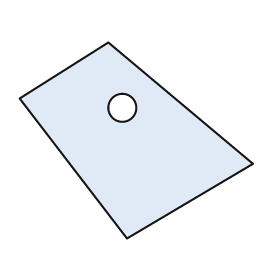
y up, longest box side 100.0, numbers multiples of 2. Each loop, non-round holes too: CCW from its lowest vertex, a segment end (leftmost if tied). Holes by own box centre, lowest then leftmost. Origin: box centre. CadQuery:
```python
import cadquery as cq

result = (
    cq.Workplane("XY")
    .moveTo(-4.0, -42.0)
    .lineTo(50.0, -10.0)
    .lineTo(-12.0, 42.0)
    .lineTo(-50.0, 18.0)
    .close()
    .moveTo(-6.0, 14.0)
    .circle(6.0)
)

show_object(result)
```